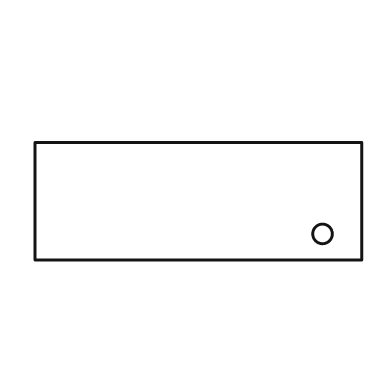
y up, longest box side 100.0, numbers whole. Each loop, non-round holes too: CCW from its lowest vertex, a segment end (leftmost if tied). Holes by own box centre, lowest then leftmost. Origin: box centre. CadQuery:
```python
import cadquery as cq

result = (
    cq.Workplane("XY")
    .moveTo(-50.0, -18.0)
    .lineTo(50.0, -18.0)
    .lineTo(50.0, 18.0)
    .lineTo(-50.0, 18.0)
    .close()
    .moveTo(38.0, -10.0)
    .circle(3.0)
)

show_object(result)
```